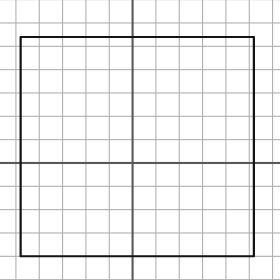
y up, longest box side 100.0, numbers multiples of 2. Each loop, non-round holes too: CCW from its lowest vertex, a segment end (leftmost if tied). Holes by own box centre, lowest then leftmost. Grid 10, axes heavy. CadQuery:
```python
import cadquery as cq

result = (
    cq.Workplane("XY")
    .moveTo(-48.0, -40.0)
    .lineTo(52.0, -40.0)
    .lineTo(52.0, 54.0)
    .lineTo(-48.0, 54.0)
    .close()
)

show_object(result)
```